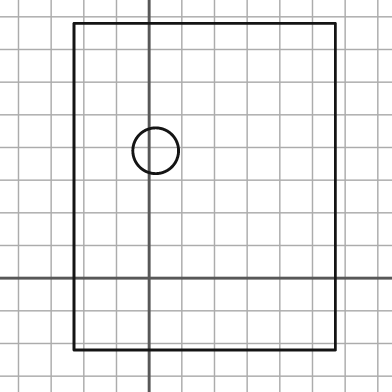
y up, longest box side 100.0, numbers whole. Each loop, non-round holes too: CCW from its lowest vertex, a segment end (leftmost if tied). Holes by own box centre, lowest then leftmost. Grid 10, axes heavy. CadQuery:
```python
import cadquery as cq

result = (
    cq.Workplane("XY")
    .moveTo(-23.0, -22.0)
    .lineTo(57.0, -22.0)
    .lineTo(57.0, 78.0)
    .lineTo(-23.0, 78.0)
    .close()
    .moveTo(2.0, 39.0)
    .circle(7.0)
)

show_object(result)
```